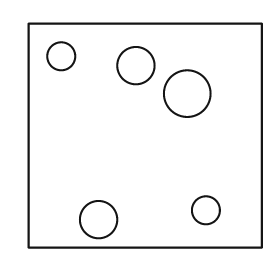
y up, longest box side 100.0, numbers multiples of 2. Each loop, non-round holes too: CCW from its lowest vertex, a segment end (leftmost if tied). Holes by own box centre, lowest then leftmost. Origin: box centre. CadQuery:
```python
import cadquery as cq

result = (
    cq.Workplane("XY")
    .moveTo(-50.0, -48.0)
    .lineTo(50.0, -48.0)
    .lineTo(50.0, 48.0)
    .lineTo(-50.0, 48.0)
    .close()
    .moveTo(-20.0, -36.0)
    .circle(8.0)
    .moveTo(26.0, -32.0)
    .circle(6.0)
    .moveTo(18.0, 18.0)
    .circle(10.0)
    .moveTo(-4.0, 30.0)
    .circle(8.0)
    .moveTo(-36.0, 34.0)
    .circle(6.0)
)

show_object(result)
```